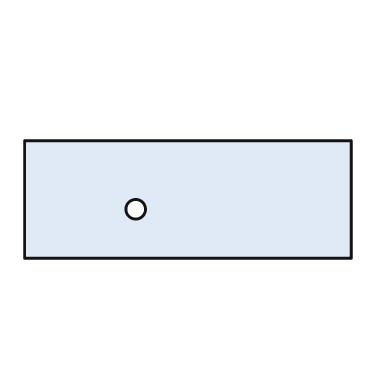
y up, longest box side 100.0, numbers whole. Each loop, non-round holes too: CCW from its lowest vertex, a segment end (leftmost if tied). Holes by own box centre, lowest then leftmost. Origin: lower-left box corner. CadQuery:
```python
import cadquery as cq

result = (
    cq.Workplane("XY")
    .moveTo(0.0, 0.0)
    .lineTo(100.0, 0.0)
    .lineTo(100.0, 36.0)
    .lineTo(0.0, 36.0)
    .close()
    .moveTo(34.0, 15.0)
    .circle(3.0)
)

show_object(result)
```